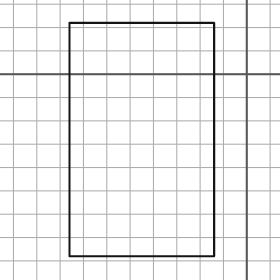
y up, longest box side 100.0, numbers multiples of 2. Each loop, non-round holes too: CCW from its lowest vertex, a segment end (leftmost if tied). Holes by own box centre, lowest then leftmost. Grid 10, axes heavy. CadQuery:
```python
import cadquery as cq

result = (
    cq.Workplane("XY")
    .moveTo(-76.0, -78.0)
    .lineTo(-14.0, -78.0)
    .lineTo(-14.0, 22.0)
    .lineTo(-76.0, 22.0)
    .close()
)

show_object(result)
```